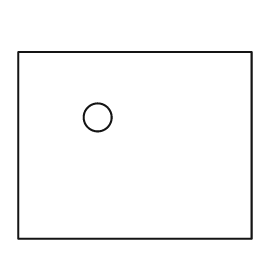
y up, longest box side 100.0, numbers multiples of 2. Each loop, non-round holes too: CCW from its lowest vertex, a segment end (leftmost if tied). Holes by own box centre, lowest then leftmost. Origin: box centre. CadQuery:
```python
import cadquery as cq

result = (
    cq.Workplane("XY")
    .moveTo(-50.0, -40.0)
    .lineTo(50.0, -40.0)
    .lineTo(50.0, 40.0)
    .lineTo(-50.0, 40.0)
    .close()
    .moveTo(-16.0, 12.0)
    .circle(6.0)
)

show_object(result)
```